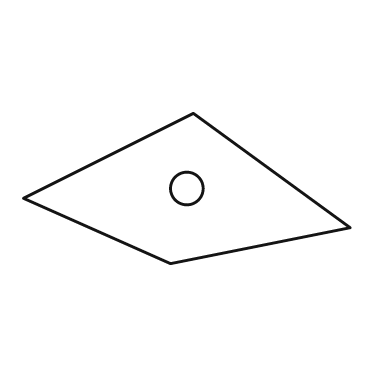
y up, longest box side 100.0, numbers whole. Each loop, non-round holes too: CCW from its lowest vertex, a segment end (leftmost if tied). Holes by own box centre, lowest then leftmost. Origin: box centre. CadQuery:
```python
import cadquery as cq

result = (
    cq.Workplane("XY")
    .moveTo(-5.0, -23.0)
    .lineTo(50.0, -12.0)
    .lineTo(2.0, 23.0)
    .lineTo(-50.0, -3.0)
    .close()
    .moveTo(0.0, 0.0)
    .circle(5.0)
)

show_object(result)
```